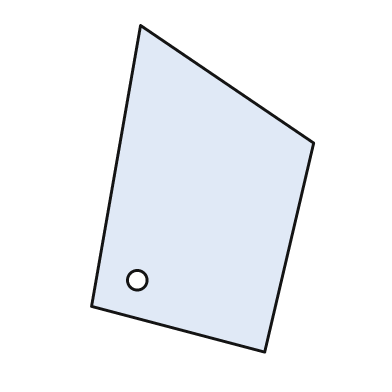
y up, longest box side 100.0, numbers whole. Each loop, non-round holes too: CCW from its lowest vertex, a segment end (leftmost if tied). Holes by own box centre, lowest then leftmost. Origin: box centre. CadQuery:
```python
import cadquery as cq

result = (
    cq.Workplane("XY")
    .moveTo(19.0, -50.0)
    .lineTo(34.0, 14.0)
    .lineTo(-19.0, 50.0)
    .lineTo(-34.0, -36.0)
    .close()
    .moveTo(-20.0, -28.0)
    .circle(3.0)
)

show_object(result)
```